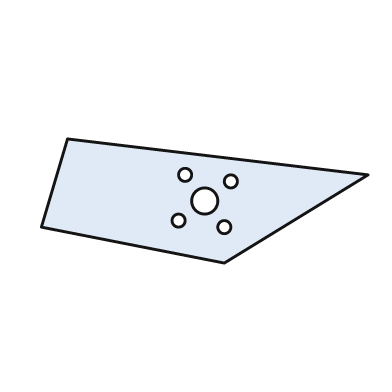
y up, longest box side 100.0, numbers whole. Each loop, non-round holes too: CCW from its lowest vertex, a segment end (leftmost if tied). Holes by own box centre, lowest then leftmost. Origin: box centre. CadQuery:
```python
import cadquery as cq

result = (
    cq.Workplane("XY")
    .moveTo(6.0, -19.0)
    .lineTo(50.0, 8.0)
    .lineTo(-42.0, 19.0)
    .lineTo(-50.0, -8.0)
    .close()
    .moveTo(6.0, -8.0)
    .circle(2.0)
    .moveTo(-8.0, -6.0)
    .circle(2.0)
    .moveTo(0.0, 0.0)
    .circle(4.0)
    .moveTo(8.0, 6.0)
    .circle(2.0)
    .moveTo(-6.0, 8.0)
    .circle(2.0)
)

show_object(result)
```